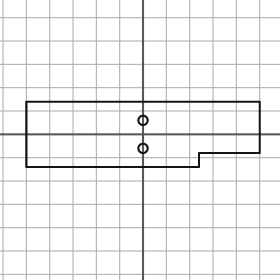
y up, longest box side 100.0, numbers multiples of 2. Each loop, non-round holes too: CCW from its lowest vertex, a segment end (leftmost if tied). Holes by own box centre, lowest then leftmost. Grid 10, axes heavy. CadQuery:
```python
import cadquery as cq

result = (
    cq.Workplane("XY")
    .moveTo(-50.0, -14.0)
    .lineTo(24.0, -14.0)
    .lineTo(24.0, -8.0)
    .lineTo(50.0, -8.0)
    .lineTo(50.0, 14.0)
    .lineTo(-50.0, 14.0)
    .close()
    .moveTo(0.0, -6.0)
    .circle(2.0)
    .moveTo(0.0, 6.0)
    .circle(2.0)
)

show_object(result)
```